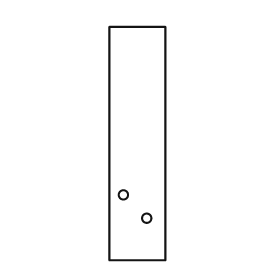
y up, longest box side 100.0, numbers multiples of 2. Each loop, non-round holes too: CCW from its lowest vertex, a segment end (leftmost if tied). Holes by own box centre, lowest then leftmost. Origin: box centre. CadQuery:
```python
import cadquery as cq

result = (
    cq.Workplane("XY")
    .moveTo(-12.0, -50.0)
    .lineTo(12.0, -50.0)
    .lineTo(12.0, 50.0)
    .lineTo(-12.0, 50.0)
    .close()
    .moveTo(4.0, -32.0)
    .circle(2.0)
    .moveTo(-6.0, -22.0)
    .circle(2.0)
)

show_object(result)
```